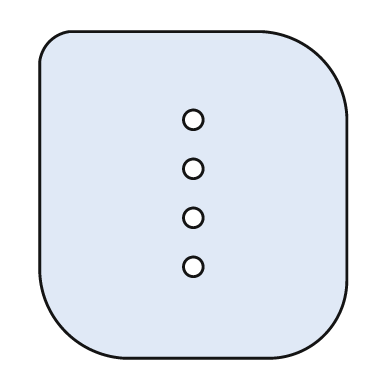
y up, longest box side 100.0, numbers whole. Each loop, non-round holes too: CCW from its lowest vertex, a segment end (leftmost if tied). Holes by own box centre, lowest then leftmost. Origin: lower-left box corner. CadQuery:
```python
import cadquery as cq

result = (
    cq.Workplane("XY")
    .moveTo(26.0, 0.0)
    .lineTo(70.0, 0.0)
    .threePointArc((87.0, 7.0), (94.0, 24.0))
    .lineTo(94.0, 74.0)
    .threePointArc((86.0, 92.0), (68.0, 100.0))
    .lineTo(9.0, 100.0)
    .threePointArc((3.0, 97.0), (0.0, 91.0))
    .lineTo(0.0, 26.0)
    .threePointArc((8.0, 8.0), (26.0, 0.0))
    .close()
    .moveTo(47.0, 28.0)
    .circle(3.0)
    .moveTo(47.0, 43.0)
    .circle(3.0)
    .moveTo(47.0, 58.0)
    .circle(3.0)
    .moveTo(47.0, 73.0)
    .circle(3.0)
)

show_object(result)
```